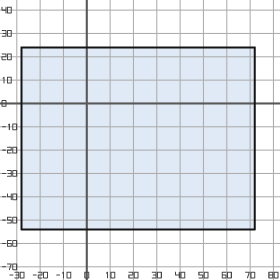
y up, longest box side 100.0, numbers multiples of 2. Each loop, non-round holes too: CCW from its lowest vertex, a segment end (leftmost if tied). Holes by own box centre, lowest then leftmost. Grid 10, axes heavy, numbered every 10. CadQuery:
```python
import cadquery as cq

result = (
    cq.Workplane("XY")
    .moveTo(-28.0, -54.0)
    .lineTo(72.0, -54.0)
    .lineTo(72.0, 24.0)
    .lineTo(-28.0, 24.0)
    .close()
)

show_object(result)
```